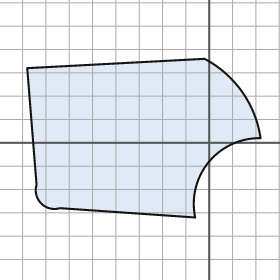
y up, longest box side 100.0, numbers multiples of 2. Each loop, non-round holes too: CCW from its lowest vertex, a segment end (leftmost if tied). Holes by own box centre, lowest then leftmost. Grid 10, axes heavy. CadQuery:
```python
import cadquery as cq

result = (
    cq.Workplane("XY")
    .moveTo(-6.0, -32.0)
    .threePointArc((0.0, -8.0), (22.0, 2.0))
    .threePointArc((14.0, 22.0), (-2.0, 36.0))
    .lineTo(-78.0, 32.0)
    .lineTo(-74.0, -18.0)
    .threePointArc((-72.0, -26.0), (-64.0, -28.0))
    .close()
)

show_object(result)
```